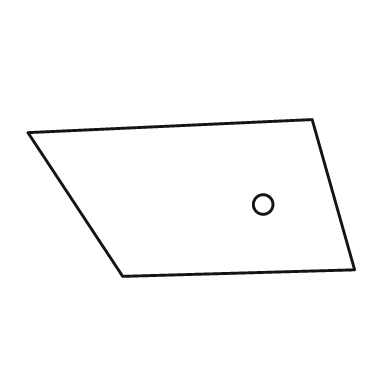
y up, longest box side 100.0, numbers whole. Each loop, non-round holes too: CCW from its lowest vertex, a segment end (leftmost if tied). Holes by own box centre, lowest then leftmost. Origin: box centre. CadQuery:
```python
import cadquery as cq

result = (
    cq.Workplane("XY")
    .moveTo(-21.0, -24.0)
    .lineTo(50.0, -22.0)
    .lineTo(37.0, 24.0)
    .lineTo(-50.0, 20.0)
    .close()
    .moveTo(22.0, -2.0)
    .circle(3.0)
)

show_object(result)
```